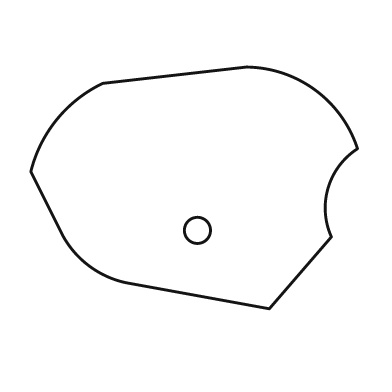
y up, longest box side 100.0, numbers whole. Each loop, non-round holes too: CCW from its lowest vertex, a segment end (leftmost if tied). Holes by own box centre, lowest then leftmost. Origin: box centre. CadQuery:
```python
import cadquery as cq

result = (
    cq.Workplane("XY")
    .moveTo(23.0, -37.0)
    .lineTo(42.0, -15.0)
    .threePointArc((41.0, 0.0), (50.0, 12.0))
    .threePointArc((37.0, 30.0), (16.0, 37.0))
    .lineTo(-28.0, 32.0)
    .threePointArc((-42.0, 21.0), (-50.0, 5.0))
    .lineTo(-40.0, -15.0)
    .threePointArc((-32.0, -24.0), (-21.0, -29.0))
    .close()
    .moveTo(1.0, -13.0)
    .circle(4.0)
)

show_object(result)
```